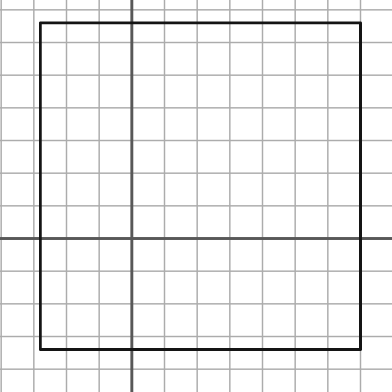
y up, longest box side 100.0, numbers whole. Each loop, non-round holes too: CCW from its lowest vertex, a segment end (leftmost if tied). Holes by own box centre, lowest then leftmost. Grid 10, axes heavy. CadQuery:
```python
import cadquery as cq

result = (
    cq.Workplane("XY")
    .moveTo(-28.0, -34.0)
    .lineTo(70.0, -34.0)
    .lineTo(70.0, 66.0)
    .lineTo(-28.0, 66.0)
    .close()
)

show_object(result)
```